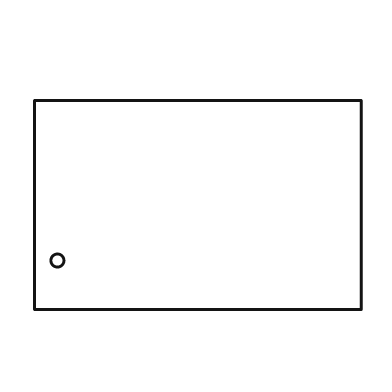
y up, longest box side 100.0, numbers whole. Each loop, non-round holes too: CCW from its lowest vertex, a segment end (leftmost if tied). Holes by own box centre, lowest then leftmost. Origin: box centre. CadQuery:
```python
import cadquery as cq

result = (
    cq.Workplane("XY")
    .moveTo(-50.0, -32.0)
    .lineTo(50.0, -32.0)
    .lineTo(50.0, 32.0)
    .lineTo(-50.0, 32.0)
    .close()
    .moveTo(-43.0, -17.0)
    .circle(2.0)
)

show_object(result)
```